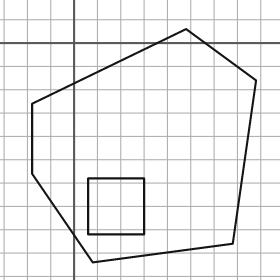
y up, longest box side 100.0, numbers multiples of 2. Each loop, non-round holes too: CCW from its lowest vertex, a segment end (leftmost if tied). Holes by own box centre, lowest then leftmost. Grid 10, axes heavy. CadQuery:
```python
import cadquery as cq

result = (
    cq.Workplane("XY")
    .moveTo(8.0, -94.0)
    .lineTo(68.0, -86.0)
    .lineTo(78.0, -16.0)
    .lineTo(48.0, 6.0)
    .lineTo(-18.0, -26.0)
    .lineTo(-18.0, -56.0)
    .close()
    .moveTo(6.0, -82.0)
    .lineTo(30.0, -82.0)
    .lineTo(30.0, -58.0)
    .lineTo(6.0, -58.0)
    .close()
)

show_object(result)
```